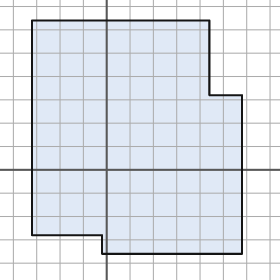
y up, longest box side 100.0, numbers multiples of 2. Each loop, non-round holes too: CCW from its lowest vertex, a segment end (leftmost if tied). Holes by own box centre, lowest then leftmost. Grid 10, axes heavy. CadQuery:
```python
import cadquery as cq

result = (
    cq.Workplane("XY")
    .moveTo(-2.0, -36.0)
    .lineTo(58.0, -36.0)
    .lineTo(58.0, 32.0)
    .lineTo(44.0, 32.0)
    .lineTo(44.0, 64.0)
    .lineTo(-32.0, 64.0)
    .lineTo(-32.0, -28.0)
    .lineTo(-2.0, -28.0)
    .close()
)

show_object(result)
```